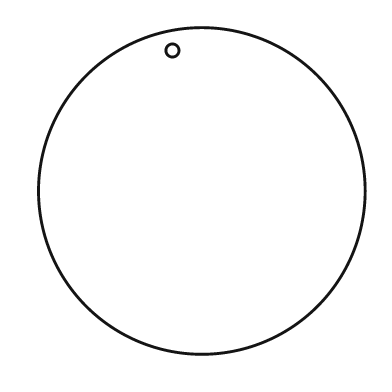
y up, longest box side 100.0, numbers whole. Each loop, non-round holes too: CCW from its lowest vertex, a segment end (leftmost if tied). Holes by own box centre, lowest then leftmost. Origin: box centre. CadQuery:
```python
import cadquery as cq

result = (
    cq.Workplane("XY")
    .moveTo(0.0, 0.0)
    .circle(50.0)
    .moveTo(-9.0, 43.0)
    .circle(2.0)
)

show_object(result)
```